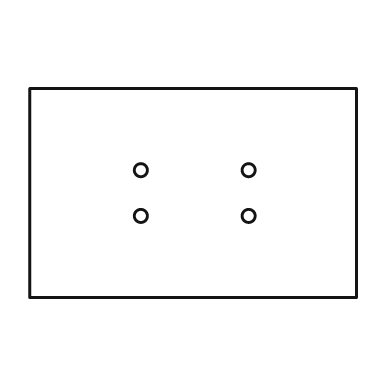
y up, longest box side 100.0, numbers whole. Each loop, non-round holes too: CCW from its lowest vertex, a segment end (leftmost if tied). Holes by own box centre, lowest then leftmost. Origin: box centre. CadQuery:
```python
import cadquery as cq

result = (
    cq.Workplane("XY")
    .moveTo(-50.0, -32.0)
    .lineTo(50.0, -32.0)
    .lineTo(50.0, 32.0)
    .lineTo(-50.0, 32.0)
    .close()
    .moveTo(-16.0, -7.0)
    .circle(2.0)
    .moveTo(17.0, -7.0)
    .circle(2.0)
    .moveTo(-16.0, 7.0)
    .circle(2.0)
    .moveTo(17.0, 7.0)
    .circle(2.0)
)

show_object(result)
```